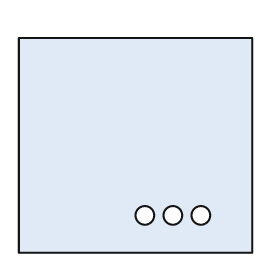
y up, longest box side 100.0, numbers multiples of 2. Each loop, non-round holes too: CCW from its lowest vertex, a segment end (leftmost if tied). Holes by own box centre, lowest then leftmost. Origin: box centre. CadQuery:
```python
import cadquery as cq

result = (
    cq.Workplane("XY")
    .moveTo(-50.0, -46.0)
    .lineTo(50.0, -46.0)
    .lineTo(50.0, 46.0)
    .lineTo(-50.0, 46.0)
    .close()
    .moveTo(4.0, -30.0)
    .circle(4.0)
    .moveTo(16.0, -30.0)
    .circle(4.0)
    .moveTo(28.0, -30.0)
    .circle(4.0)
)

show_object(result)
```